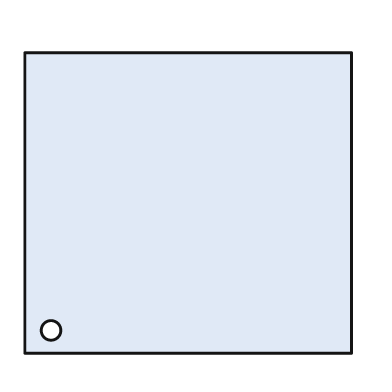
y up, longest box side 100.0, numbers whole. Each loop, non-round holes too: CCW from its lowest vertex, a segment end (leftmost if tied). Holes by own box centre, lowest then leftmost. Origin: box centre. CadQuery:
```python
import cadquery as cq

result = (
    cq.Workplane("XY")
    .moveTo(-50.0, -46.0)
    .lineTo(50.0, -46.0)
    .lineTo(50.0, 46.0)
    .lineTo(-50.0, 46.0)
    .close()
    .moveTo(-42.0, -39.0)
    .circle(3.0)
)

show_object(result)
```